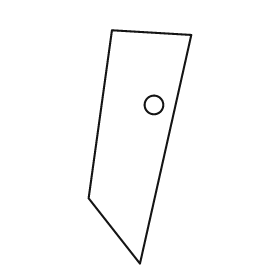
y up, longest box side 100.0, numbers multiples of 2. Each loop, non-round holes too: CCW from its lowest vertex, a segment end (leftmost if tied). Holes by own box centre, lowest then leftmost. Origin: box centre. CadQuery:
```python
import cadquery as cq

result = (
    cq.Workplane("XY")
    .moveTo(0.0, -50.0)
    .lineTo(22.0, 48.0)
    .lineTo(-12.0, 50.0)
    .lineTo(-22.0, -22.0)
    .close()
    .moveTo(6.0, 18.0)
    .circle(4.0)
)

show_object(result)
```